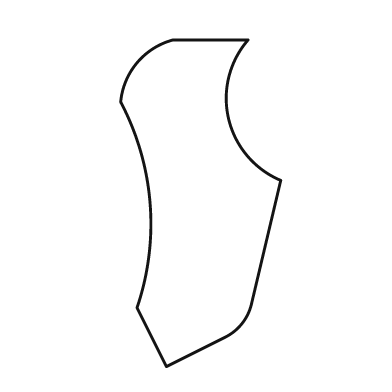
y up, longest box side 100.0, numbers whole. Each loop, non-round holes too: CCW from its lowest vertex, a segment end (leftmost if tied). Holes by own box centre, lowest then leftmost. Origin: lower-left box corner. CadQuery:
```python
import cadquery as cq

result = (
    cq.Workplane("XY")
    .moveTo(14.0, 0.0)
    .lineTo(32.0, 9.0)
    .threePointArc((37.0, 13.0), (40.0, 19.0))
    .lineTo(49.0, 57.0)
    .threePointArc((33.0, 76.0), (39.0, 100.0))
    .lineTo(16.0, 100.0)
    .threePointArc((5.0, 93.0), (0.0, 81.0))
    .threePointArc((9.0, 50.0), (5.0, 18.0))
    .close()
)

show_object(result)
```